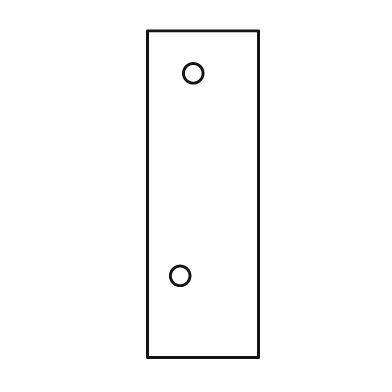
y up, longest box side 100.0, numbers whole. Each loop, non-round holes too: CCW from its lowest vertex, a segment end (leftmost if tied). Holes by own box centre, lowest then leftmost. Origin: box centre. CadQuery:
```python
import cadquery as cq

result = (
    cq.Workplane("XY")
    .moveTo(-17.0, -50.0)
    .lineTo(17.0, -50.0)
    .lineTo(17.0, 50.0)
    .lineTo(-17.0, 50.0)
    .close()
    .moveTo(-7.0, -25.0)
    .circle(3.0)
    .moveTo(-3.0, 37.0)
    .circle(3.0)
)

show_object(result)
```